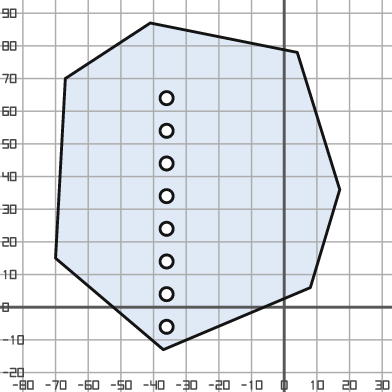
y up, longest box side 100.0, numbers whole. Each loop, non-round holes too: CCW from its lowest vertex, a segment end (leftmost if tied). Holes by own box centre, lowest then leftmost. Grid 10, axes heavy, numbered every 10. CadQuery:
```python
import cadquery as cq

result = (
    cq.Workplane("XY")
    .moveTo(-37.0, -13.0)
    .lineTo(8.0, 6.0)
    .lineTo(17.0, 36.0)
    .lineTo(4.0, 78.0)
    .lineTo(-41.0, 87.0)
    .lineTo(-67.0, 70.0)
    .lineTo(-70.0, 15.0)
    .close()
    .moveTo(-36.0, -6.0)
    .circle(2.0)
    .moveTo(-36.0, 4.0)
    .circle(2.0)
    .moveTo(-36.0, 14.0)
    .circle(2.0)
    .moveTo(-36.0, 24.0)
    .circle(2.0)
    .moveTo(-36.0, 34.0)
    .circle(2.0)
    .moveTo(-36.0, 44.0)
    .circle(2.0)
    .moveTo(-36.0, 54.0)
    .circle(2.0)
    .moveTo(-36.0, 64.0)
    .circle(2.0)
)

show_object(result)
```